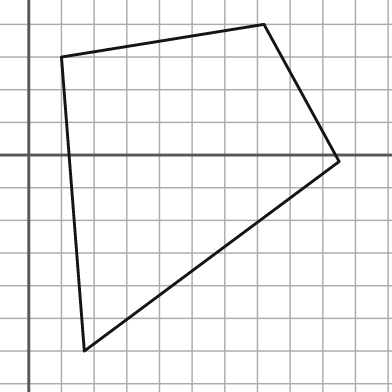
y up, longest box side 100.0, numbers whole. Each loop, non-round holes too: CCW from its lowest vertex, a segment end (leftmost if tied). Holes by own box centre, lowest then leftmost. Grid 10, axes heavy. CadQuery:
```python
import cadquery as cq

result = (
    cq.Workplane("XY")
    .moveTo(17.0, -60.0)
    .lineTo(95.0, -2.0)
    .lineTo(72.0, 40.0)
    .lineTo(10.0, 30.0)
    .close()
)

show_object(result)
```